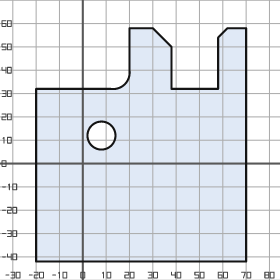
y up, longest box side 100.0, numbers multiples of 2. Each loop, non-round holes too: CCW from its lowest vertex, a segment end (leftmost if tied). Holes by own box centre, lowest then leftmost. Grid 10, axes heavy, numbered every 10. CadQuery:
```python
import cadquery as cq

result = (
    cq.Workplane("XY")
    .moveTo(-20.0, -42.0)
    .lineTo(70.0, -42.0)
    .lineTo(70.0, 58.0)
    .lineTo(62.0, 58.0)
    .lineTo(58.0, 54.0)
    .lineTo(58.0, 32.0)
    .lineTo(38.0, 32.0)
    .lineTo(38.0, 50.0)
    .lineTo(30.0, 58.0)
    .lineTo(20.0, 58.0)
    .lineTo(20.0, 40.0)
    .threePointArc((18.0, 34.0), (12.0, 32.0))
    .lineTo(-20.0, 32.0)
    .close()
    .moveTo(8.0, 12.0)
    .circle(6.0)
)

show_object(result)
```